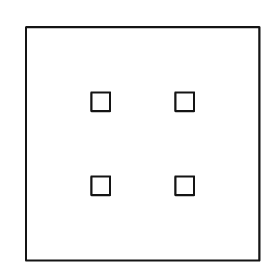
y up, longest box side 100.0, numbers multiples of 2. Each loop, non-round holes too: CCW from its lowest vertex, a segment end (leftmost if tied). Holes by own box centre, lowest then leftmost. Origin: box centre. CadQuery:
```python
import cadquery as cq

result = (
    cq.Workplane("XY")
    .moveTo(-50.0, -50.0)
    .lineTo(50.0, -50.0)
    .lineTo(50.0, 50.0)
    .lineTo(-50.0, 50.0)
    .close()
    .moveTo(-22.0, -22.0)
    .lineTo(-14.0, -22.0)
    .lineTo(-14.0, -14.0)
    .lineTo(-22.0, -14.0)
    .close()
    .moveTo(14.0, -22.0)
    .lineTo(22.0, -22.0)
    .lineTo(22.0, -14.0)
    .lineTo(14.0, -14.0)
    .close()
    .moveTo(-22.0, 14.0)
    .lineTo(-14.0, 14.0)
    .lineTo(-14.0, 22.0)
    .lineTo(-22.0, 22.0)
    .close()
    .moveTo(14.0, 14.0)
    .lineTo(22.0, 14.0)
    .lineTo(22.0, 22.0)
    .lineTo(14.0, 22.0)
    .close()
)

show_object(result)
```